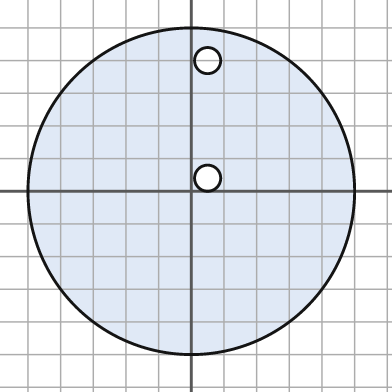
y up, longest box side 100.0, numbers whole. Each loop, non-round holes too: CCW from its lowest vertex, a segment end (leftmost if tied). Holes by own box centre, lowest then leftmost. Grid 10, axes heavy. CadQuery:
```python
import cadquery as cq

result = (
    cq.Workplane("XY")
    .moveTo(0.0, 0.0)
    .circle(50.0)
    .moveTo(5.0, 4.0)
    .circle(4.0)
    .moveTo(5.0, 40.0)
    .circle(4.0)
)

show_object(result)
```